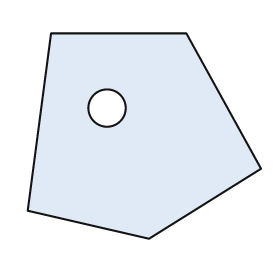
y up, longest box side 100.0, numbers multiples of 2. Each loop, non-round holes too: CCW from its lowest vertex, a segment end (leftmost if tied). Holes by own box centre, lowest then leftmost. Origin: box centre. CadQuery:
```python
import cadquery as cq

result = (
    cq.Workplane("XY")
    .moveTo(2.0, -44.0)
    .lineTo(50.0, -14.0)
    .lineTo(18.0, 44.0)
    .lineTo(-40.0, 44.0)
    .lineTo(-50.0, -32.0)
    .close()
    .moveTo(-16.0, 12.0)
    .circle(8.0)
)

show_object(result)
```